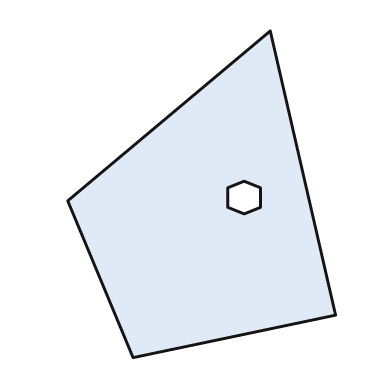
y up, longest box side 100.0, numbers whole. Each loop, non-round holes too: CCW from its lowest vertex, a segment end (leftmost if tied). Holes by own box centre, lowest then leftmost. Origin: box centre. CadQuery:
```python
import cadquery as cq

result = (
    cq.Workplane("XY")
    .moveTo(-21.0, -50.0)
    .lineTo(41.0, -37.0)
    .lineTo(21.0, 50.0)
    .lineTo(-41.0, -2.0)
    .close()
    .moveTo(13.0, -6.0)
    .lineTo(18.0, -4.0)
    .lineTo(18.0, 2.0)
    .lineTo(13.0, 4.0)
    .lineTo(8.0, 2.0)
    .lineTo(8.0, -4.0)
    .close()
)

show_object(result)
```